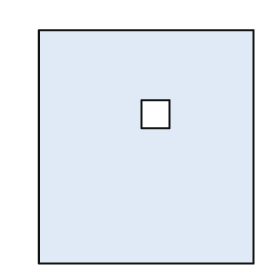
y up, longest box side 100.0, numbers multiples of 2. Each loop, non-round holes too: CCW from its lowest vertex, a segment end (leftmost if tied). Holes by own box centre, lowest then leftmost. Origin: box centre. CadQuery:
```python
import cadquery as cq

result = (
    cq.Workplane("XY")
    .moveTo(-46.0, -50.0)
    .lineTo(46.0, -50.0)
    .lineTo(46.0, 50.0)
    .lineTo(-46.0, 50.0)
    .close()
    .moveTo(-2.0, 8.0)
    .lineTo(10.0, 8.0)
    .lineTo(10.0, 20.0)
    .lineTo(-2.0, 20.0)
    .close()
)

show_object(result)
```